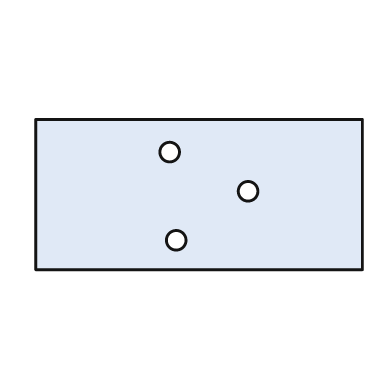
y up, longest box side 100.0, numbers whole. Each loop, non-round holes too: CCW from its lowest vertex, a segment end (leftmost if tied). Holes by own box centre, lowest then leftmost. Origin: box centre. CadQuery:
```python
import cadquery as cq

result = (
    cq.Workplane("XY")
    .moveTo(-50.0, -23.0)
    .lineTo(50.0, -23.0)
    .lineTo(50.0, 23.0)
    .lineTo(-50.0, 23.0)
    .close()
    .moveTo(-7.0, -14.0)
    .circle(3.0)
    .moveTo(15.0, 1.0)
    .circle(3.0)
    .moveTo(-9.0, 13.0)
    .circle(3.0)
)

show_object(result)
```